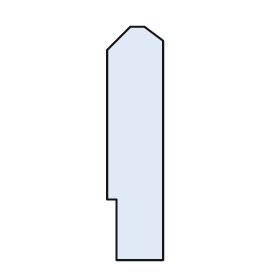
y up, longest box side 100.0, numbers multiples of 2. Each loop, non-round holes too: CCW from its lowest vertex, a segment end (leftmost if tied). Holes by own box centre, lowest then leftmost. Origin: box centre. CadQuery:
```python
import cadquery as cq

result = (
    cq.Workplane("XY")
    .moveTo(-8.0, -50.0)
    .lineTo(12.0, -50.0)
    .lineTo(12.0, 44.0)
    .lineTo(4.0, 50.0)
    .lineTo(-2.0, 50.0)
    .lineTo(-12.0, 40.0)
    .lineTo(-12.0, -24.0)
    .lineTo(-8.0, -24.0)
    .close()
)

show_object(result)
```